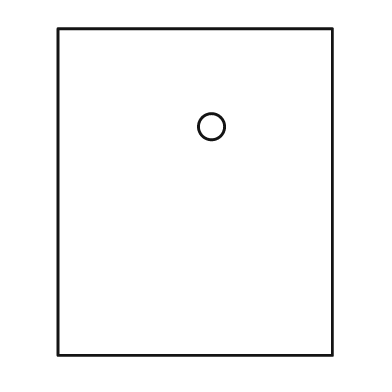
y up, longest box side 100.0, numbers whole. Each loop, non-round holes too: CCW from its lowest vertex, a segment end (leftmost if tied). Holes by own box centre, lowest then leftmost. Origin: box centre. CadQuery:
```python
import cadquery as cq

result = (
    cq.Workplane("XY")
    .moveTo(-42.0, -50.0)
    .lineTo(42.0, -50.0)
    .lineTo(42.0, 50.0)
    .lineTo(-42.0, 50.0)
    .close()
    .moveTo(5.0, 20.0)
    .circle(4.0)
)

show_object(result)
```